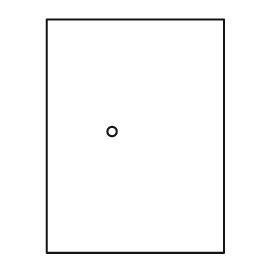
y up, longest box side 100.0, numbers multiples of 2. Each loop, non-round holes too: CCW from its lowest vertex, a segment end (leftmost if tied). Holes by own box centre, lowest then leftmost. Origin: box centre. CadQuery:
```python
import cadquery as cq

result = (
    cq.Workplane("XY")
    .moveTo(-38.0, -50.0)
    .lineTo(38.0, -50.0)
    .lineTo(38.0, 50.0)
    .lineTo(-38.0, 50.0)
    .close()
    .moveTo(-10.0, 2.0)
    .circle(2.0)
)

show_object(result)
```